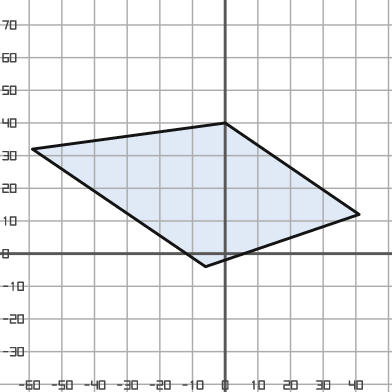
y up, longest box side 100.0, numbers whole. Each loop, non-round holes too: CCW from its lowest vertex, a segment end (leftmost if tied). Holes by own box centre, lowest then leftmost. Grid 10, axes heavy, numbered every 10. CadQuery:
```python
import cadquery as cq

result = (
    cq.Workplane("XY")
    .moveTo(-6.0, -4.0)
    .lineTo(41.0, 12.0)
    .lineTo(0.0, 40.0)
    .lineTo(-59.0, 32.0)
    .close()
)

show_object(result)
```